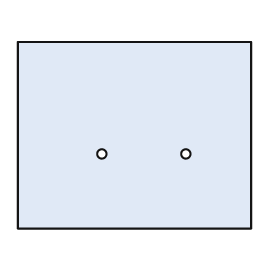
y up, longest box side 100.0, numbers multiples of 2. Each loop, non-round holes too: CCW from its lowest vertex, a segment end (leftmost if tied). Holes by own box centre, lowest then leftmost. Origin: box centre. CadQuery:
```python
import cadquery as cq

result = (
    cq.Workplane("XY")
    .moveTo(-50.0, -40.0)
    .lineTo(50.0, -40.0)
    .lineTo(50.0, 40.0)
    .lineTo(-50.0, 40.0)
    .close()
    .moveTo(-14.0, -8.0)
    .circle(2.0)
    .moveTo(22.0, -8.0)
    .circle(2.0)
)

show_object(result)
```